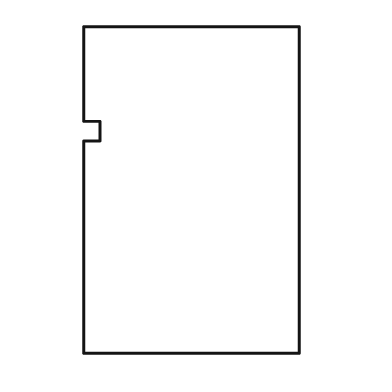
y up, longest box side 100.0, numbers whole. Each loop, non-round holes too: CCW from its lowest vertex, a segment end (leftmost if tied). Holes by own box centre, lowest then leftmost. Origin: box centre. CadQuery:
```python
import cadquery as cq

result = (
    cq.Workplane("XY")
    .moveTo(-33.0, -50.0)
    .lineTo(33.0, -50.0)
    .lineTo(33.0, 50.0)
    .lineTo(-33.0, 50.0)
    .lineTo(-33.0, 21.0)
    .lineTo(-28.0, 21.0)
    .lineTo(-28.0, 15.0)
    .lineTo(-33.0, 15.0)
    .close()
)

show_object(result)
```